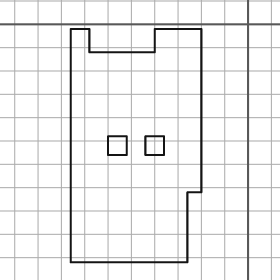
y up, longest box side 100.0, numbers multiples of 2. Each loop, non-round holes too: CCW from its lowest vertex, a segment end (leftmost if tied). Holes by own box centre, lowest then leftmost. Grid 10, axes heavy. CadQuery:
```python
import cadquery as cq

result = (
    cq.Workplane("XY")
    .moveTo(-76.0, -102.0)
    .lineTo(-26.0, -102.0)
    .lineTo(-26.0, -72.0)
    .lineTo(-20.0, -72.0)
    .lineTo(-20.0, -2.0)
    .lineTo(-40.0, -2.0)
    .lineTo(-40.0, -12.0)
    .lineTo(-68.0, -12.0)
    .lineTo(-68.0, -2.0)
    .lineTo(-76.0, -2.0)
    .close()
    .moveTo(-60.0, -56.0)
    .lineTo(-52.0, -56.0)
    .lineTo(-52.0, -48.0)
    .lineTo(-60.0, -48.0)
    .close()
    .moveTo(-44.0, -56.0)
    .lineTo(-36.0, -56.0)
    .lineTo(-36.0, -48.0)
    .lineTo(-44.0, -48.0)
    .close()
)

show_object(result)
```